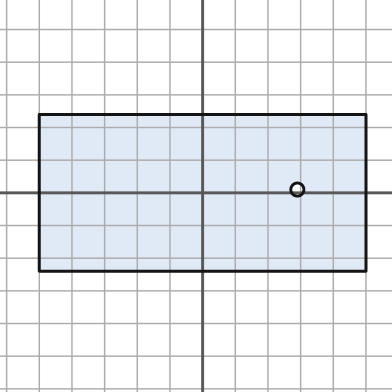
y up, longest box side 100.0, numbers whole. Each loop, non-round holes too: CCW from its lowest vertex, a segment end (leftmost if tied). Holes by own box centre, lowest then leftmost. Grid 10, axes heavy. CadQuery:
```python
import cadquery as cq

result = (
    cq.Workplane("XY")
    .moveTo(-50.0, -24.0)
    .lineTo(50.0, -24.0)
    .lineTo(50.0, 24.0)
    .lineTo(-50.0, 24.0)
    .close()
    .moveTo(29.0, 1.0)
    .circle(2.0)
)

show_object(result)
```